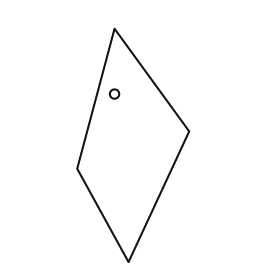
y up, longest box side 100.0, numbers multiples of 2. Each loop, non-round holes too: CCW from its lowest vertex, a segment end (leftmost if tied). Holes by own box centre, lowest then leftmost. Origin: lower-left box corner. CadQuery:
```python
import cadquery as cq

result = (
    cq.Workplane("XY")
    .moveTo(22.0, 0.0)
    .lineTo(48.0, 56.0)
    .lineTo(16.0, 100.0)
    .lineTo(0.0, 40.0)
    .close()
    .moveTo(16.0, 72.0)
    .circle(2.0)
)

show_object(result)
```